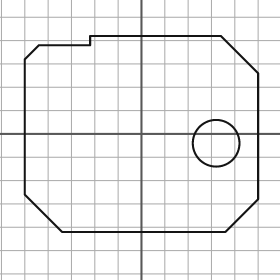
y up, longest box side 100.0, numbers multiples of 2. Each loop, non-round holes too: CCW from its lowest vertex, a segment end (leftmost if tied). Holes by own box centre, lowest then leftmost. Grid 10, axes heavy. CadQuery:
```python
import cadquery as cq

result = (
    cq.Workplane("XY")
    .moveTo(-34.0, -42.0)
    .lineTo(36.0, -42.0)
    .lineTo(50.0, -28.0)
    .lineTo(50.0, 26.0)
    .lineTo(34.0, 42.0)
    .lineTo(-22.0, 42.0)
    .lineTo(-22.0, 38.0)
    .lineTo(-44.0, 38.0)
    .lineTo(-50.0, 32.0)
    .lineTo(-50.0, -26.0)
    .close()
    .moveTo(32.0, -4.0)
    .circle(10.0)
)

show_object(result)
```